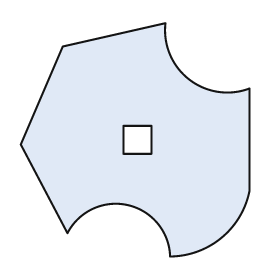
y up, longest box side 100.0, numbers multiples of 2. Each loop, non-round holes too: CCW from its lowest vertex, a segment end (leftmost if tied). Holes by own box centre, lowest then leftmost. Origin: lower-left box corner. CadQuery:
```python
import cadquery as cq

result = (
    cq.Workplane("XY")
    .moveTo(64.0, 0.0)
    .threePointArc((86.0, 8.0), (98.0, 28.0))
    .lineTo(98.0, 72.0)
    .threePointArc((72.0, 76.0), (62.0, 100.0))
    .lineTo(18.0, 90.0)
    .lineTo(0.0, 48.0)
    .lineTo(20.0, 10.0)
    .threePointArc((46.0, 22.0), (64.0, 0.0))
    .close()
    .moveTo(44.0, 44.0)
    .lineTo(56.0, 44.0)
    .lineTo(56.0, 56.0)
    .lineTo(44.0, 56.0)
    .close()
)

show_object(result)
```